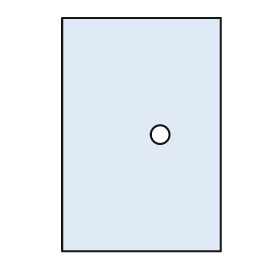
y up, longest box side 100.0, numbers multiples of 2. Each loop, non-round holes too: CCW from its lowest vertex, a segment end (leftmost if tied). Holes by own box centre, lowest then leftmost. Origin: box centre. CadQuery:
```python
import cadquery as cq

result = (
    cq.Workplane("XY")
    .moveTo(-34.0, -50.0)
    .lineTo(34.0, -50.0)
    .lineTo(34.0, 50.0)
    .lineTo(-34.0, 50.0)
    .close()
    .moveTo(8.0, 0.0)
    .circle(4.0)
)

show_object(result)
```